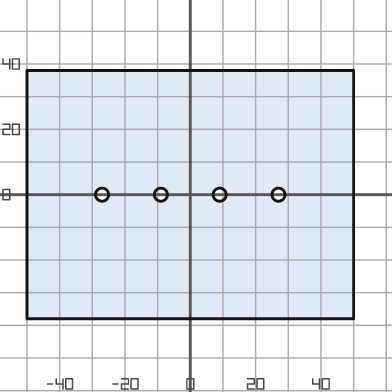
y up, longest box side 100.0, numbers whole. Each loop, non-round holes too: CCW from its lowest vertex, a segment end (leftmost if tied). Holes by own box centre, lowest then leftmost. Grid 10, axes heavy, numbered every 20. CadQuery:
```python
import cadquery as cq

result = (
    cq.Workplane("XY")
    .moveTo(-50.0, -38.0)
    .lineTo(50.0, -38.0)
    .lineTo(50.0, 38.0)
    .lineTo(-50.0, 38.0)
    .close()
    .moveTo(-27.0, 0.0)
    .circle(2.0)
    .moveTo(-9.0, 0.0)
    .circle(2.0)
    .moveTo(9.0, 0.0)
    .circle(2.0)
    .moveTo(27.0, 0.0)
    .circle(2.0)
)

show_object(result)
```